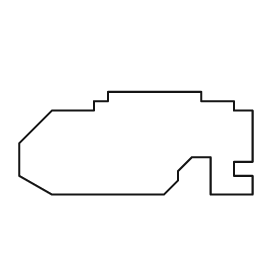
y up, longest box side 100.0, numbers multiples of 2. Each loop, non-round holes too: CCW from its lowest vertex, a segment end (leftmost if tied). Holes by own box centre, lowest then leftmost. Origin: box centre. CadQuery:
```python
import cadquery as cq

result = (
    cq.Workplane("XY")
    .moveTo(-36.0, -22.0)
    .lineTo(12.0, -22.0)
    .lineTo(18.0, -16.0)
    .lineTo(18.0, -12.0)
    .lineTo(24.0, -6.0)
    .lineTo(32.0, -6.0)
    .lineTo(32.0, -22.0)
    .lineTo(50.0, -22.0)
    .lineTo(50.0, -14.0)
    .lineTo(42.0, -14.0)
    .lineTo(42.0, -8.0)
    .lineTo(50.0, -8.0)
    .lineTo(50.0, 14.0)
    .lineTo(42.0, 14.0)
    .lineTo(42.0, 18.0)
    .lineTo(28.0, 18.0)
    .lineTo(28.0, 22.0)
    .lineTo(-12.0, 22.0)
    .lineTo(-12.0, 18.0)
    .lineTo(-18.0, 18.0)
    .lineTo(-18.0, 14.0)
    .lineTo(-36.0, 14.0)
    .lineTo(-50.0, 0.0)
    .lineTo(-50.0, -14.0)
    .close()
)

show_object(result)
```